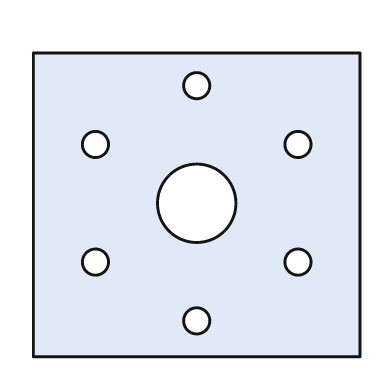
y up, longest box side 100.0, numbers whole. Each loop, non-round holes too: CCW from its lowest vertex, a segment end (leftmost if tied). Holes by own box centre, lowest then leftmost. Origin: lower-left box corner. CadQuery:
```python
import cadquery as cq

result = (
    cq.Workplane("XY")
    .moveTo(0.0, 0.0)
    .lineTo(100.0, 0.0)
    .lineTo(100.0, 93.0)
    .lineTo(0.0, 93.0)
    .close()
    .moveTo(50.0, 11.0)
    .circle(4.0)
    .moveTo(19.0, 29.0)
    .circle(4.0)
    .moveTo(81.0, 29.0)
    .circle(4.0)
    .moveTo(50.0, 47.0)
    .circle(12.0)
    .moveTo(19.0, 65.0)
    .circle(4.0)
    .moveTo(81.0, 65.0)
    .circle(4.0)
    .moveTo(50.0, 83.0)
    .circle(4.0)
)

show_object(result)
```